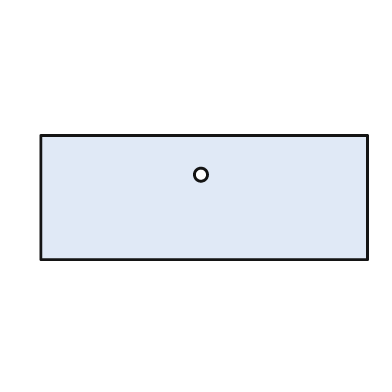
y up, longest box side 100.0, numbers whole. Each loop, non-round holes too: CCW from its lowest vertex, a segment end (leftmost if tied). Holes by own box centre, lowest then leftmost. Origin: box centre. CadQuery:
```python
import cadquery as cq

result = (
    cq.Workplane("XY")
    .moveTo(-50.0, -19.0)
    .lineTo(50.0, -19.0)
    .lineTo(50.0, 19.0)
    .lineTo(-50.0, 19.0)
    .close()
    .moveTo(-1.0, 7.0)
    .circle(2.0)
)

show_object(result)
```